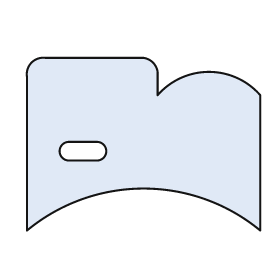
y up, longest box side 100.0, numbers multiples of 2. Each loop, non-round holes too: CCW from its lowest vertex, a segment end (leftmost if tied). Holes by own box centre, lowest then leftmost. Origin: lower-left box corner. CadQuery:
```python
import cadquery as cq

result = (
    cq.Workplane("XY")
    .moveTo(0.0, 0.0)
    .threePointArc((50.0, 18.0), (100.0, 0.0))
    .lineTo(100.0, 58.0)
    .threePointArc((78.0, 68.0), (56.0, 58.0))
    .lineTo(56.0, 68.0)
    .threePointArc((54.0, 72.0), (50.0, 74.0))
    .lineTo(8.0, 74.0)
    .threePointArc((2.0, 72.0), (0.0, 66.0))
    .close()
    .moveTo(18.0, 30.0)
    .lineTo(30.0, 30.0)
    .threePointArc((34.0, 34.0), (30.0, 38.0))
    .lineTo(18.0, 38.0)
    .threePointArc((14.0, 34.0), (18.0, 30.0))
    .close()
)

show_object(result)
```